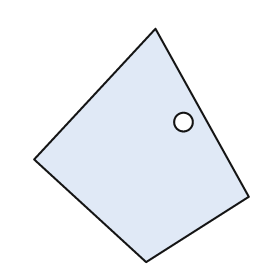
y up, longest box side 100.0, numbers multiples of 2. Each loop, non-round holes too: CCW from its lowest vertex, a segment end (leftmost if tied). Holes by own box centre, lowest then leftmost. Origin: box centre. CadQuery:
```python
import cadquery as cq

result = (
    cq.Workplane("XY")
    .moveTo(2.0, -50.0)
    .lineTo(46.0, -22.0)
    .lineTo(6.0, 50.0)
    .lineTo(-46.0, -6.0)
    .close()
    .moveTo(18.0, 10.0)
    .circle(4.0)
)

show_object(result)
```